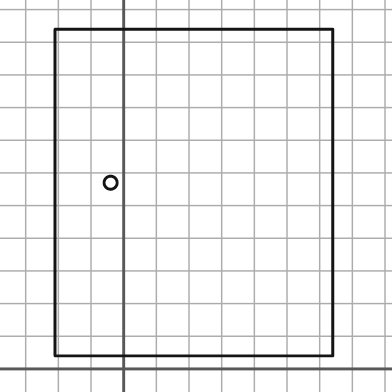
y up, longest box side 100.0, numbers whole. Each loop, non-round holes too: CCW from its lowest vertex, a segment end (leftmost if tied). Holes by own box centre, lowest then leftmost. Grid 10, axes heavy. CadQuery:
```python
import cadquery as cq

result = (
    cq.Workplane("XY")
    .moveTo(-21.0, 4.0)
    .lineTo(64.0, 4.0)
    .lineTo(64.0, 104.0)
    .lineTo(-21.0, 104.0)
    .close()
    .moveTo(-4.0, 57.0)
    .circle(2.0)
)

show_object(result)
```